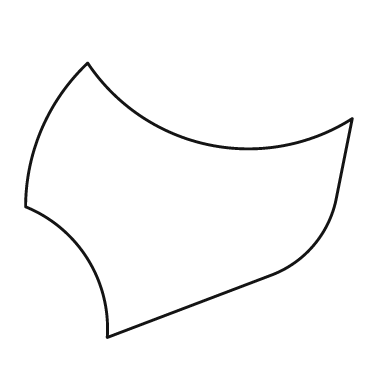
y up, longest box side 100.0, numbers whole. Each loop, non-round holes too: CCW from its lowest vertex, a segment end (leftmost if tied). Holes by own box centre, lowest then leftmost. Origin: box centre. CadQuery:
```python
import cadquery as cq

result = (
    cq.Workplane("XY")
    .moveTo(-25.0, -42.0)
    .lineTo(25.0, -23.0)
    .threePointArc((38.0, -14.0), (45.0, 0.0))
    .lineTo(50.0, 25.0)
    .threePointArc((6.0, 17.0), (-31.0, 42.0))
    .threePointArc((-45.0, 22.0), (-50.0, -2.0))
    .threePointArc((-31.0, -18.0), (-25.0, -42.0))
    .close()
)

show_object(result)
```